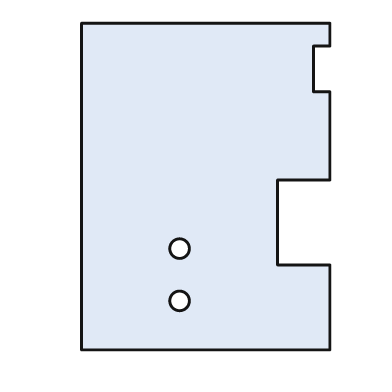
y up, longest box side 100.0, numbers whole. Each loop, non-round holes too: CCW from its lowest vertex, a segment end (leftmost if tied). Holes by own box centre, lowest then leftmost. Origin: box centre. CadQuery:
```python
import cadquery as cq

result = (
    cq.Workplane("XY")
    .moveTo(-38.0, -50.0)
    .lineTo(38.0, -50.0)
    .lineTo(38.0, -24.0)
    .lineTo(22.0, -24.0)
    .lineTo(22.0, 2.0)
    .lineTo(38.0, 2.0)
    .lineTo(38.0, 29.0)
    .lineTo(33.0, 29.0)
    .lineTo(33.0, 43.0)
    .lineTo(38.0, 43.0)
    .lineTo(38.0, 50.0)
    .lineTo(-38.0, 50.0)
    .close()
    .moveTo(-8.0, -35.0)
    .circle(3.0)
    .moveTo(-8.0, -19.0)
    .circle(3.0)
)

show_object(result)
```